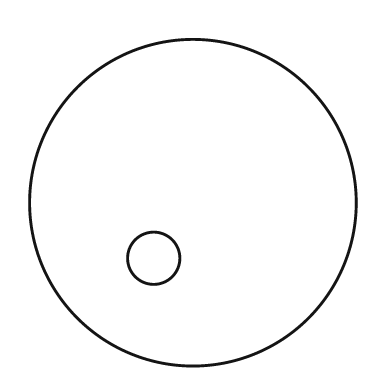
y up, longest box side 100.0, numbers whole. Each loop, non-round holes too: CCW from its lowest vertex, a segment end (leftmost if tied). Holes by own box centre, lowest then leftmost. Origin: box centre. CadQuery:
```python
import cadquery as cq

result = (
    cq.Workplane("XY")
    .moveTo(0.0, 0.0)
    .circle(50.0)
    .moveTo(-12.0, -17.0)
    .circle(8.0)
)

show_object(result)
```